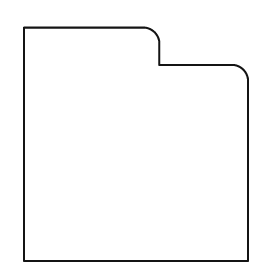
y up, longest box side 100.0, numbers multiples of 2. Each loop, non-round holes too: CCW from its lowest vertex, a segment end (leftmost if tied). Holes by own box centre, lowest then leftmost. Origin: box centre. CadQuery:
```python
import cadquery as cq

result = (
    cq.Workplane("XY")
    .moveTo(-48.0, -50.0)
    .lineTo(48.0, -50.0)
    .lineTo(48.0, 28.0)
    .threePointArc((46.0, 32.0), (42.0, 34.0))
    .lineTo(10.0, 34.0)
    .lineTo(10.0, 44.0)
    .threePointArc((8.0, 48.0), (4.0, 50.0))
    .lineTo(-48.0, 50.0)
    .close()
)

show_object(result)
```